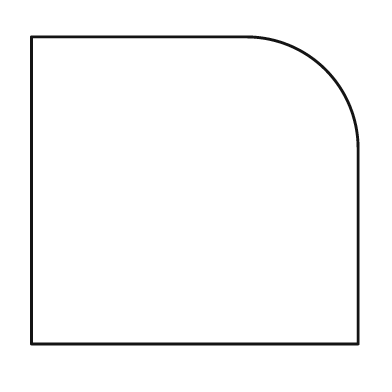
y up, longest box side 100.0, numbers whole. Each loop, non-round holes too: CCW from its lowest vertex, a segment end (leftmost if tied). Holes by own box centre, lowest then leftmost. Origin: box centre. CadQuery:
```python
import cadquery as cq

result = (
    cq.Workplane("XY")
    .moveTo(-50.0, -47.0)
    .lineTo(50.0, -47.0)
    .lineTo(50.0, 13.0)
    .threePointArc((40.0, 37.0), (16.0, 47.0))
    .lineTo(-50.0, 47.0)
    .close()
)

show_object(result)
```